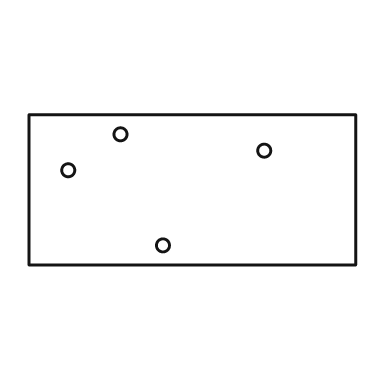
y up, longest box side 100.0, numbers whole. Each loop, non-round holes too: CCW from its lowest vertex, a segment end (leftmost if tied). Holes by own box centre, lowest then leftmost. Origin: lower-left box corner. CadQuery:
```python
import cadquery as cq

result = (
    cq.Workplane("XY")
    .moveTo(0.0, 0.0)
    .lineTo(100.0, 0.0)
    .lineTo(100.0, 46.0)
    .lineTo(0.0, 46.0)
    .close()
    .moveTo(41.0, 6.0)
    .circle(2.0)
    .moveTo(12.0, 29.0)
    .circle(2.0)
    .moveTo(72.0, 35.0)
    .circle(2.0)
    .moveTo(28.0, 40.0)
    .circle(2.0)
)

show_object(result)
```